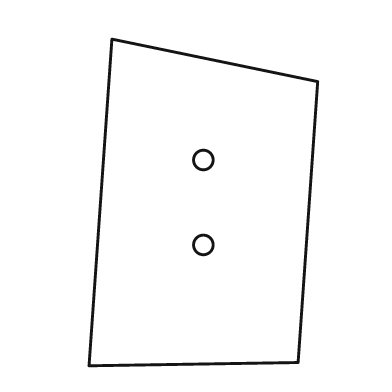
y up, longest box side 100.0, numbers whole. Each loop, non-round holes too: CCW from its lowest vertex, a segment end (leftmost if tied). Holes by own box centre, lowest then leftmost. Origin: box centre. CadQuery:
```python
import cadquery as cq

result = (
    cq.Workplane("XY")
    .moveTo(-35.0, -50.0)
    .lineTo(29.0, -49.0)
    .lineTo(35.0, 37.0)
    .lineTo(-28.0, 50.0)
    .close()
    .moveTo(0.0, -13.0)
    .circle(3.0)
    .moveTo(0.0, 13.0)
    .circle(3.0)
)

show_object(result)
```